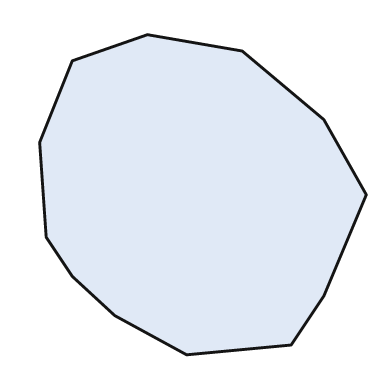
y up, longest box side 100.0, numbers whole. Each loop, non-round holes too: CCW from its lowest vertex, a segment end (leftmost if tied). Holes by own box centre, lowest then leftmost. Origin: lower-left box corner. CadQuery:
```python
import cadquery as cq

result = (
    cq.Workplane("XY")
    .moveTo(45.0, 0.0)
    .lineTo(77.0, 3.0)
    .lineTo(87.0, 18.0)
    .lineTo(100.0, 49.0)
    .lineTo(87.0, 72.0)
    .lineTo(62.0, 93.0)
    .lineTo(33.0, 98.0)
    .lineTo(10.0, 90.0)
    .lineTo(0.0, 65.0)
    .lineTo(2.0, 36.0)
    .lineTo(10.0, 24.0)
    .lineTo(23.0, 12.0)
    .close()
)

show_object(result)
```